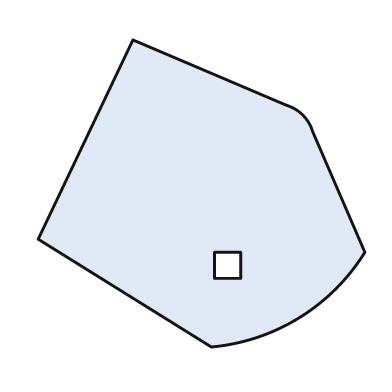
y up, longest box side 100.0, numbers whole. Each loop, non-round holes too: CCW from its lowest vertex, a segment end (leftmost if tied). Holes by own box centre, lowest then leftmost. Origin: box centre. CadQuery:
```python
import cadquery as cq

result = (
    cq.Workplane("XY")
    .moveTo(3.0, -47.0)
    .threePointArc((30.0, -38.0), (50.0, -18.0))
    .lineTo(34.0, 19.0)
    .threePointArc((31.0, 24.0), (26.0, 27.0))
    .lineTo(-21.0, 47.0)
    .lineTo(-50.0, -14.0)
    .close()
    .moveTo(4.0, -26.0)
    .lineTo(12.0, -26.0)
    .lineTo(12.0, -18.0)
    .lineTo(4.0, -18.0)
    .close()
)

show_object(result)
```